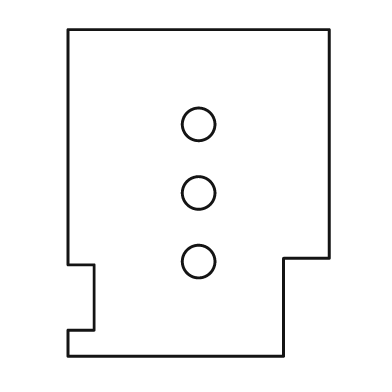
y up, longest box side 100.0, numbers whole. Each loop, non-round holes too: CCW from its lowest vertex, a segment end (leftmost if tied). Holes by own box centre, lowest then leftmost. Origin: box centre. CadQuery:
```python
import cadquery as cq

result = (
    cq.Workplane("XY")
    .moveTo(-40.0, -50.0)
    .lineTo(26.0, -50.0)
    .lineTo(26.0, -20.0)
    .lineTo(40.0, -20.0)
    .lineTo(40.0, 50.0)
    .lineTo(-40.0, 50.0)
    .lineTo(-40.0, -22.0)
    .lineTo(-32.0, -22.0)
    .lineTo(-32.0, -42.0)
    .lineTo(-40.0, -42.0)
    .close()
    .moveTo(0.0, -21.0)
    .circle(5.0)
    .moveTo(0.0, 0.0)
    .circle(5.0)
    .moveTo(0.0, 21.0)
    .circle(5.0)
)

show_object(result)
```